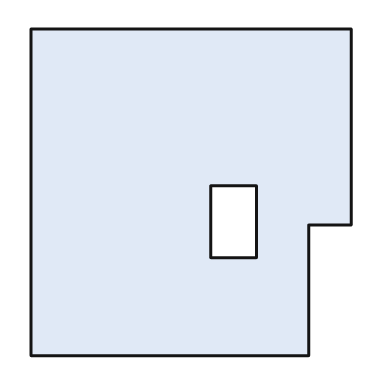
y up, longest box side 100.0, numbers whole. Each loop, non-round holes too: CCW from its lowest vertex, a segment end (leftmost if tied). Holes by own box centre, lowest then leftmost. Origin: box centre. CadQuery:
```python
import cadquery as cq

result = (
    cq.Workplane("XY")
    .moveTo(-49.0, -50.0)
    .lineTo(36.0, -50.0)
    .lineTo(36.0, -10.0)
    .lineTo(49.0, -10.0)
    .lineTo(49.0, 50.0)
    .lineTo(-49.0, 50.0)
    .close()
    .moveTo(6.0, -20.0)
    .lineTo(20.0, -20.0)
    .lineTo(20.0, 2.0)
    .lineTo(6.0, 2.0)
    .close()
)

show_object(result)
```